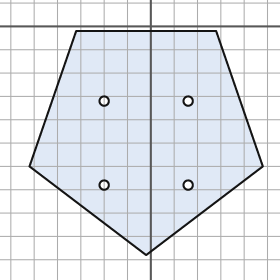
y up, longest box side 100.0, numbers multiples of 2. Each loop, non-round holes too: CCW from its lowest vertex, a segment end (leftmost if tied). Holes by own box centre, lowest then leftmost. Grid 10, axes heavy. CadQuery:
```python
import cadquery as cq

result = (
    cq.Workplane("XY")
    .moveTo(-2.0, -98.0)
    .lineTo(48.0, -60.0)
    .lineTo(28.0, -2.0)
    .lineTo(-32.0, -2.0)
    .lineTo(-52.0, -60.0)
    .close()
    .moveTo(-20.0, -68.0)
    .circle(2.0)
    .moveTo(16.0, -68.0)
    .circle(2.0)
    .moveTo(-20.0, -32.0)
    .circle(2.0)
    .moveTo(16.0, -32.0)
    .circle(2.0)
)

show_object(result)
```